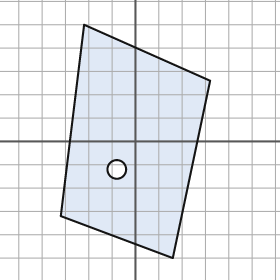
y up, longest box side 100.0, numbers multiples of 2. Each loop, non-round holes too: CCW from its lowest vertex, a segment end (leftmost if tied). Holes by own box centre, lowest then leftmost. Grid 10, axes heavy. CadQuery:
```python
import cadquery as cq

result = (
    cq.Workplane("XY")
    .moveTo(16.0, -50.0)
    .lineTo(32.0, 26.0)
    .lineTo(-22.0, 50.0)
    .lineTo(-32.0, -32.0)
    .close()
    .moveTo(-8.0, -12.0)
    .circle(4.0)
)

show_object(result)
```